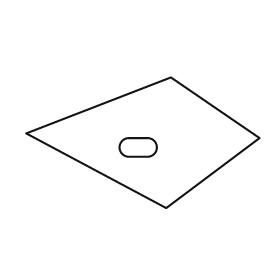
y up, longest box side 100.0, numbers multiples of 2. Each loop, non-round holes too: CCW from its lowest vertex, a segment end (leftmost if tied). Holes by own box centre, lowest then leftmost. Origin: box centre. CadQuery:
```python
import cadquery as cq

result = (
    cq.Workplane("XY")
    .moveTo(10.0, -28.0)
    .lineTo(50.0, 2.0)
    .lineTo(12.0, 28.0)
    .lineTo(-50.0, 4.0)
    .close()
    .moveTo(-6.0, -6.0)
    .lineTo(2.0, -6.0)
    .threePointArc((6.0, -2.0), (2.0, 2.0))
    .lineTo(-6.0, 2.0)
    .threePointArc((-10.0, -2.0), (-6.0, -6.0))
    .close()
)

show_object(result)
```